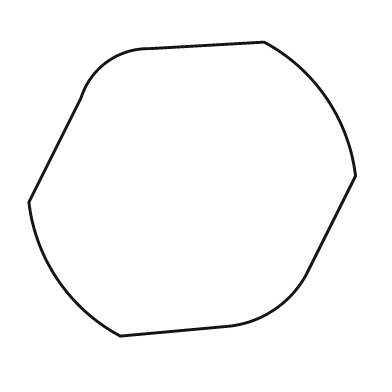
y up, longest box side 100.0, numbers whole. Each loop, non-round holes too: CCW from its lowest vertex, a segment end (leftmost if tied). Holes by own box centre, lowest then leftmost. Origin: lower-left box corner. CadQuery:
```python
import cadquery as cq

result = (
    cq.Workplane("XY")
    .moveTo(28.0, 0.0)
    .lineTo(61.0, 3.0)
    .threePointArc((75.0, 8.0), (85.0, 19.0))
    .lineTo(100.0, 49.0)
    .threePointArc((91.0, 73.0), (72.0, 90.0))
    .lineTo(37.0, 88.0)
    .threePointArc((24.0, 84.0), (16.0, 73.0))
    .lineTo(0.0, 41.0)
    .threePointArc((9.0, 17.0), (28.0, 0.0))
    .close()
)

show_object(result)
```